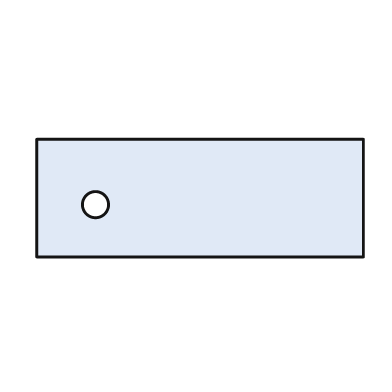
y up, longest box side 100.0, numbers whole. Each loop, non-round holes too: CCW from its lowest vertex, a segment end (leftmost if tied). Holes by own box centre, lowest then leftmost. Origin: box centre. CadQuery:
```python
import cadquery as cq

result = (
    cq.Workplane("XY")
    .moveTo(-50.0, -18.0)
    .lineTo(50.0, -18.0)
    .lineTo(50.0, 18.0)
    .lineTo(-50.0, 18.0)
    .close()
    .moveTo(-32.0, -2.0)
    .circle(4.0)
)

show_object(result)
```